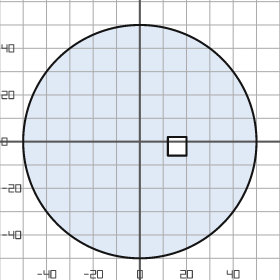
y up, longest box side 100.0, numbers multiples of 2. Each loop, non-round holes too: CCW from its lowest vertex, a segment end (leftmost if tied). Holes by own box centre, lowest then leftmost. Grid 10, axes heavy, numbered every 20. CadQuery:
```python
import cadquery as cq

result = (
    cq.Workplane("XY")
    .moveTo(0.0, 0.0)
    .circle(50.0)
    .moveTo(12.0, -6.0)
    .lineTo(20.0, -6.0)
    .lineTo(20.0, 2.0)
    .lineTo(12.0, 2.0)
    .close()
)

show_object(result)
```